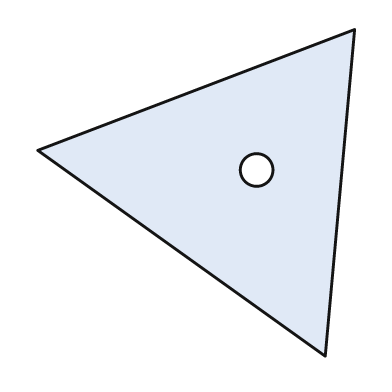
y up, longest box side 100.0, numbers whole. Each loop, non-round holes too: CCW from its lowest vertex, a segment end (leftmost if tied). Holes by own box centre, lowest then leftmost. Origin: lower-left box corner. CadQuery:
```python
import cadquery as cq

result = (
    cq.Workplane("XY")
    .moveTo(88.0, 0.0)
    .lineTo(97.0, 100.0)
    .lineTo(0.0, 63.0)
    .close()
    .moveTo(67.0, 57.0)
    .circle(5.0)
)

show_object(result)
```